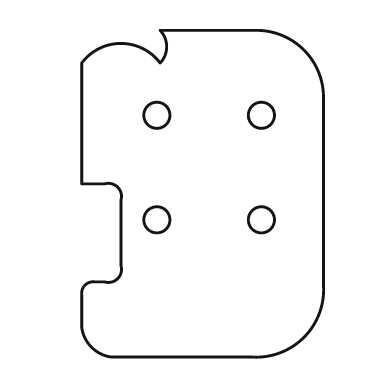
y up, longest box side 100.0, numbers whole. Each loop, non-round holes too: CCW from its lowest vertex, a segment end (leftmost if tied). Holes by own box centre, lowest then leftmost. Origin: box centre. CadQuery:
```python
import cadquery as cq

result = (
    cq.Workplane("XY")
    .moveTo(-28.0, -50.0)
    .lineTo(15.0, -50.0)
    .threePointArc((31.0, -44.0), (37.0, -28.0))
    .lineTo(37.0, 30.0)
    .threePointArc((31.0, 44.0), (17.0, 50.0))
    .lineTo(-13.0, 50.0)
    .threePointArc((-11.0, 45.0), (-13.0, 40.0))
    .threePointArc((-25.0, 46.0), (-37.0, 40.0))
    .lineTo(-37.0, 3.0)
    .lineTo(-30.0, 3.0)
    .threePointArc((-26.0, 2.0), (-25.0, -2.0))
    .lineTo(-25.0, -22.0)
    .threePointArc((-26.0, -26.0), (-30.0, -27.0))
    .lineTo(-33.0, -27.0)
    .threePointArc((-36.0, -28.0), (-37.0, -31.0))
    .lineTo(-37.0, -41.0)
    .threePointArc((-34.0, -47.0), (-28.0, -50.0))
    .close()
    .moveTo(-14.0, -8.0)
    .circle(4.0)
    .moveTo(18.0, -8.0)
    .circle(4.0)
    .moveTo(-14.0, 24.0)
    .circle(4.0)
    .moveTo(18.0, 24.0)
    .circle(4.0)
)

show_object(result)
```